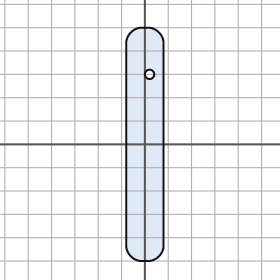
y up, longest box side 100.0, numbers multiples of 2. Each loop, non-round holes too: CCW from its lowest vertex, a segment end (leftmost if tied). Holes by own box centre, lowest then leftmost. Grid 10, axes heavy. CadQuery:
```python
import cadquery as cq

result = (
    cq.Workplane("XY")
    .moveTo(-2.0, -50.0)
    .lineTo(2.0, -50.0)
    .threePointArc((6.0, -48.0), (8.0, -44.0))
    .lineTo(8.0, 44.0)
    .threePointArc((6.0, 48.0), (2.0, 50.0))
    .lineTo(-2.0, 50.0)
    .threePointArc((-6.0, 48.0), (-8.0, 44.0))
    .lineTo(-8.0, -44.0)
    .threePointArc((-6.0, -48.0), (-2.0, -50.0))
    .close()
    .moveTo(2.0, 30.0)
    .circle(2.0)
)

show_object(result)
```